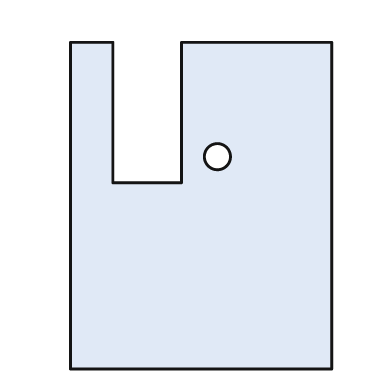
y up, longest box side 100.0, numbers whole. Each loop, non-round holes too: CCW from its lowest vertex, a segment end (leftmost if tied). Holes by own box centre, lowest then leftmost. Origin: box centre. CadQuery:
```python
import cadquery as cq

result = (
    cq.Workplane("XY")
    .moveTo(-40.0, -50.0)
    .lineTo(40.0, -50.0)
    .lineTo(40.0, 50.0)
    .lineTo(-6.0, 50.0)
    .lineTo(-6.0, 7.0)
    .lineTo(-27.0, 7.0)
    .lineTo(-27.0, 50.0)
    .lineTo(-40.0, 50.0)
    .close()
    .moveTo(5.0, 15.0)
    .circle(4.0)
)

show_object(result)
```